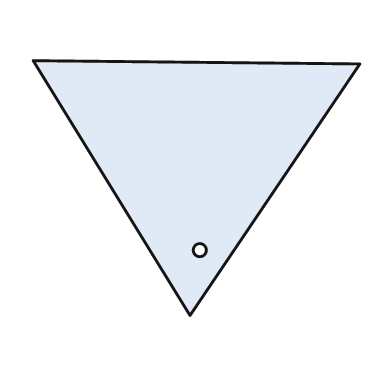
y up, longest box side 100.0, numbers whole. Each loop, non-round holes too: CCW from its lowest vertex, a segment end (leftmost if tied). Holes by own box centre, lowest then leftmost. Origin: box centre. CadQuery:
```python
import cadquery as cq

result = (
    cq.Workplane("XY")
    .moveTo(-2.0, -39.0)
    .lineTo(50.0, 38.0)
    .lineTo(-50.0, 39.0)
    .close()
    .moveTo(1.0, -19.0)
    .circle(2.0)
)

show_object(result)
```